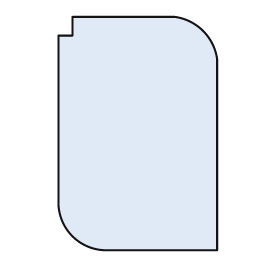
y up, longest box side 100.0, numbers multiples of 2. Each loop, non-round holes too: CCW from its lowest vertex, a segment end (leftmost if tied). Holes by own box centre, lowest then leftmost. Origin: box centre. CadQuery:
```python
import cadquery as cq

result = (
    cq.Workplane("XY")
    .moveTo(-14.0, -50.0)
    .lineTo(34.0, -50.0)
    .lineTo(34.0, 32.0)
    .threePointArc((28.0, 44.0), (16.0, 50.0))
    .lineTo(-28.0, 50.0)
    .lineTo(-28.0, 42.0)
    .lineTo(-34.0, 42.0)
    .lineTo(-34.0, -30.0)
    .threePointArc((-28.0, -44.0), (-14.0, -50.0))
    .close()
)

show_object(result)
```